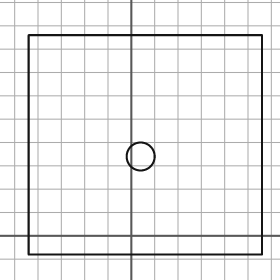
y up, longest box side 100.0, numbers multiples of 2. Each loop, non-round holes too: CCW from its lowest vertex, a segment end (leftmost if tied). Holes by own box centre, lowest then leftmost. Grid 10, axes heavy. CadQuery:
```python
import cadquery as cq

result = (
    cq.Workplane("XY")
    .moveTo(-44.0, -8.0)
    .lineTo(56.0, -8.0)
    .lineTo(56.0, 86.0)
    .lineTo(-44.0, 86.0)
    .close()
    .moveTo(4.0, 34.0)
    .circle(6.0)
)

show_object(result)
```